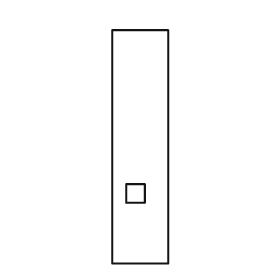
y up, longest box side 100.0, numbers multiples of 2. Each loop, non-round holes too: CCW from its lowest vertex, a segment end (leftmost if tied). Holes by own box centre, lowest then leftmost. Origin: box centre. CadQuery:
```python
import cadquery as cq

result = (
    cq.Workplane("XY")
    .moveTo(-12.0, -50.0)
    .lineTo(12.0, -50.0)
    .lineTo(12.0, 50.0)
    .lineTo(-12.0, 50.0)
    .close()
    .moveTo(-6.0, -24.0)
    .lineTo(2.0, -24.0)
    .lineTo(2.0, -16.0)
    .lineTo(-6.0, -16.0)
    .close()
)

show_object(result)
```